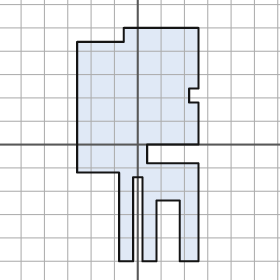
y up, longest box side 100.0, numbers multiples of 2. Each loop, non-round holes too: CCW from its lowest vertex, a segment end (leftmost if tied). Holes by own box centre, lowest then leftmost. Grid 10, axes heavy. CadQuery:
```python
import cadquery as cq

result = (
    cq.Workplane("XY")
    .moveTo(-8.0, -50.0)
    .lineTo(-2.0, -50.0)
    .lineTo(-2.0, -14.0)
    .lineTo(2.0, -14.0)
    .lineTo(2.0, -50.0)
    .lineTo(8.0, -50.0)
    .lineTo(8.0, -24.0)
    .lineTo(18.0, -24.0)
    .lineTo(18.0, -50.0)
    .lineTo(26.0, -50.0)
    .lineTo(26.0, -8.0)
    .lineTo(4.0, -8.0)
    .lineTo(4.0, 0.0)
    .lineTo(26.0, 0.0)
    .lineTo(26.0, 18.0)
    .lineTo(22.0, 18.0)
    .lineTo(22.0, 24.0)
    .lineTo(26.0, 24.0)
    .lineTo(26.0, 50.0)
    .lineTo(-6.0, 50.0)
    .lineTo(-6.0, 44.0)
    .lineTo(-26.0, 44.0)
    .lineTo(-26.0, -12.0)
    .lineTo(-8.0, -12.0)
    .close()
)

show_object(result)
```